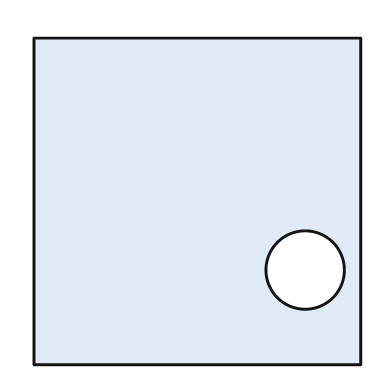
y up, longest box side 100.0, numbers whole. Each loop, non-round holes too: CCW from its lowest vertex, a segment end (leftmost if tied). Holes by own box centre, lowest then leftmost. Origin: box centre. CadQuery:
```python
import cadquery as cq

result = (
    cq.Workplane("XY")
    .moveTo(-50.0, -50.0)
    .lineTo(50.0, -50.0)
    .lineTo(50.0, 50.0)
    .lineTo(-50.0, 50.0)
    .close()
    .moveTo(33.0, -21.0)
    .circle(12.0)
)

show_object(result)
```